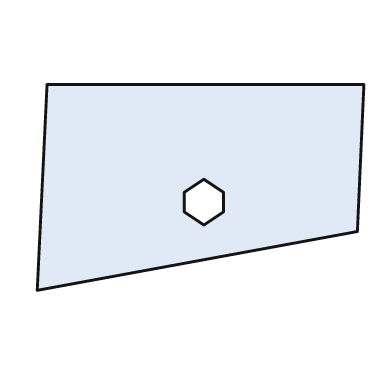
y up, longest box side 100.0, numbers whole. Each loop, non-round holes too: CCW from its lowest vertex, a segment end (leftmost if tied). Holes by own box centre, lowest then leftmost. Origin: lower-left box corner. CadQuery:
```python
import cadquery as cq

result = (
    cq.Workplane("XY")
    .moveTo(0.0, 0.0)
    .lineTo(98.0, 18.0)
    .lineTo(100.0, 63.0)
    .lineTo(3.0, 63.0)
    .close()
    .moveTo(51.0, 20.0)
    .lineTo(57.0, 24.0)
    .lineTo(57.0, 30.0)
    .lineTo(51.0, 34.0)
    .lineTo(45.0, 30.0)
    .lineTo(45.0, 24.0)
    .close()
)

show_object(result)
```